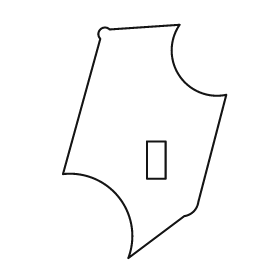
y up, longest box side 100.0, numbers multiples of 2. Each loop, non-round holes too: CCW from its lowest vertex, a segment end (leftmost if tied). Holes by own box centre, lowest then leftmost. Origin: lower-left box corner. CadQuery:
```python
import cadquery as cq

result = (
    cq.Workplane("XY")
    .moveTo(28.0, 0.0)
    .lineTo(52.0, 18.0)
    .threePointArc((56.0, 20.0), (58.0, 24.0))
    .lineTo(70.0, 70.0)
    .threePointArc((50.0, 78.0), (50.0, 100.0))
    .lineTo(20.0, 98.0)
    .threePointArc((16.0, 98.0), (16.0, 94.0))
    .lineTo(0.0, 36.0)
    .threePointArc((24.0, 26.0), (28.0, 0.0))
    .close()
    .moveTo(36.0, 34.0)
    .lineTo(44.0, 34.0)
    .lineTo(44.0, 50.0)
    .lineTo(36.0, 50.0)
    .close()
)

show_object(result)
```